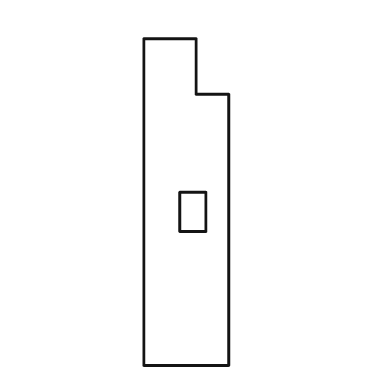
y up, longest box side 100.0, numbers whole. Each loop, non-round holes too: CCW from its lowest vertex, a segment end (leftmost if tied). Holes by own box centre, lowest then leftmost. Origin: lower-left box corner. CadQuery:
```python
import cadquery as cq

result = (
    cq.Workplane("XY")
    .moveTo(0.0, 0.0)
    .lineTo(26.0, 0.0)
    .lineTo(26.0, 83.0)
    .lineTo(16.0, 83.0)
    .lineTo(16.0, 100.0)
    .lineTo(0.0, 100.0)
    .close()
    .moveTo(11.0, 41.0)
    .lineTo(19.0, 41.0)
    .lineTo(19.0, 53.0)
    .lineTo(11.0, 53.0)
    .close()
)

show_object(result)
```